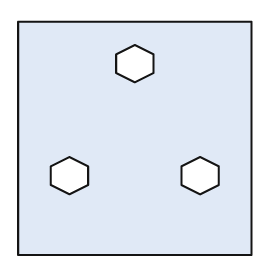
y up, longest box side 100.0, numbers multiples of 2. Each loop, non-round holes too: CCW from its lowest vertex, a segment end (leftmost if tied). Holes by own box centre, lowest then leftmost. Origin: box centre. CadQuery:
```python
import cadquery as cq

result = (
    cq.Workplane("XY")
    .moveTo(-50.0, -50.0)
    .lineTo(50.0, -50.0)
    .lineTo(50.0, 50.0)
    .lineTo(-50.0, 50.0)
    .close()
    .moveTo(-28.0, -24.0)
    .lineTo(-20.0, -20.0)
    .lineTo(-20.0, -12.0)
    .lineTo(-28.0, -8.0)
    .lineTo(-36.0, -12.0)
    .lineTo(-36.0, -20.0)
    .close()
    .moveTo(28.0, -24.0)
    .lineTo(36.0, -20.0)
    .lineTo(36.0, -12.0)
    .lineTo(28.0, -8.0)
    .lineTo(20.0, -12.0)
    .lineTo(20.0, -20.0)
    .close()
    .moveTo(0.0, 24.0)
    .lineTo(8.0, 28.0)
    .lineTo(8.0, 36.0)
    .lineTo(0.0, 40.0)
    .lineTo(-8.0, 36.0)
    .lineTo(-8.0, 28.0)
    .close()
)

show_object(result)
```